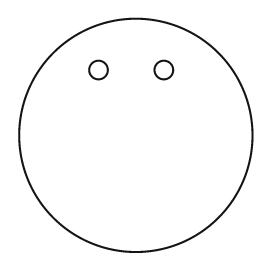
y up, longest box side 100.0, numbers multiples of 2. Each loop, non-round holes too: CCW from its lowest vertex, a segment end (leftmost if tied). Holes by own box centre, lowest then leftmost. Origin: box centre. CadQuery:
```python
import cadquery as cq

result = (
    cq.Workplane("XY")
    .moveTo(0.0, 0.0)
    .circle(50.0)
    .moveTo(-16.0, 28.0)
    .circle(4.0)
    .moveTo(12.0, 28.0)
    .circle(4.0)
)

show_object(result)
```